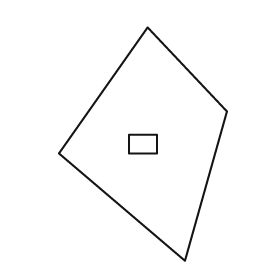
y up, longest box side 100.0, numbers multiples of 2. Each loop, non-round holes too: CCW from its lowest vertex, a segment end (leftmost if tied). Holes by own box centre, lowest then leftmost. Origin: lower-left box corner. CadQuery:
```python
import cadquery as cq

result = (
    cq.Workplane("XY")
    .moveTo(54.0, 0.0)
    .lineTo(72.0, 64.0)
    .lineTo(38.0, 100.0)
    .lineTo(0.0, 46.0)
    .close()
    .moveTo(30.0, 46.0)
    .lineTo(42.0, 46.0)
    .lineTo(42.0, 54.0)
    .lineTo(30.0, 54.0)
    .close()
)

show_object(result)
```